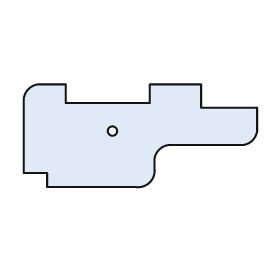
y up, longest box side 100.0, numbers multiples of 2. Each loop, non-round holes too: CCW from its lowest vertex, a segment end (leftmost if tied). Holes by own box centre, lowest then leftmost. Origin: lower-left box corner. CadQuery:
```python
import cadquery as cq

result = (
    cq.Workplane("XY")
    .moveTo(10.0, 0.0)
    .lineTo(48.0, 0.0)
    .threePointArc((54.0, 2.0), (56.0, 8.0))
    .lineTo(56.0, 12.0)
    .threePointArc((58.0, 16.0), (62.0, 18.0))
    .lineTo(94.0, 18.0)
    .threePointArc((98.0, 20.0), (100.0, 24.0))
    .lineTo(100.0, 34.0)
    .lineTo(76.0, 34.0)
    .lineTo(76.0, 44.0)
    .lineTo(54.0, 44.0)
    .lineTo(54.0, 36.0)
    .lineTo(18.0, 36.0)
    .lineTo(18.0, 44.0)
    .lineTo(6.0, 44.0)
    .threePointArc((2.0, 42.0), (0.0, 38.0))
    .lineTo(0.0, 6.0)
    .lineTo(10.0, 6.0)
    .close()
    .moveTo(38.0, 24.0)
    .circle(2.0)
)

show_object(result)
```